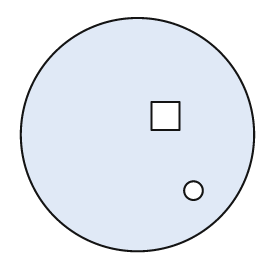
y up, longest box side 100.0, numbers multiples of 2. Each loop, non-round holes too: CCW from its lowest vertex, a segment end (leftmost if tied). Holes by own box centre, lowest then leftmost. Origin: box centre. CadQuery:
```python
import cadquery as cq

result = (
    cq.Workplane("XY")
    .moveTo(0.0, 0.0)
    .circle(50.0)
    .moveTo(24.0, -24.0)
    .circle(4.0)
    .moveTo(6.0, 2.0)
    .lineTo(18.0, 2.0)
    .lineTo(18.0, 14.0)
    .lineTo(6.0, 14.0)
    .close()
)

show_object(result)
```